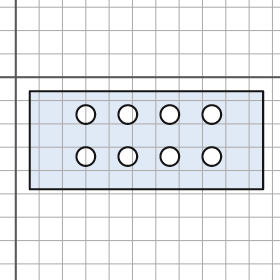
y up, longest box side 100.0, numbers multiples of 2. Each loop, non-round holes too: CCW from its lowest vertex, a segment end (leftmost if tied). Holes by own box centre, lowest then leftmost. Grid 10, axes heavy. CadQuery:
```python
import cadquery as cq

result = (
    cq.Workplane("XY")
    .moveTo(6.0, -48.0)
    .lineTo(106.0, -48.0)
    .lineTo(106.0, -6.0)
    .lineTo(6.0, -6.0)
    .close()
    .moveTo(30.0, -34.0)
    .circle(4.0)
    .moveTo(48.0, -34.0)
    .circle(4.0)
    .moveTo(66.0, -34.0)
    .circle(4.0)
    .moveTo(84.0, -34.0)
    .circle(4.0)
    .moveTo(30.0, -16.0)
    .circle(4.0)
    .moveTo(48.0, -16.0)
    .circle(4.0)
    .moveTo(66.0, -16.0)
    .circle(4.0)
    .moveTo(84.0, -16.0)
    .circle(4.0)
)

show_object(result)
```